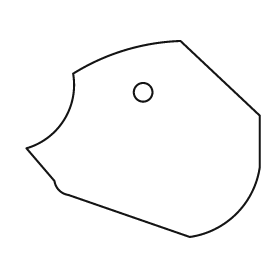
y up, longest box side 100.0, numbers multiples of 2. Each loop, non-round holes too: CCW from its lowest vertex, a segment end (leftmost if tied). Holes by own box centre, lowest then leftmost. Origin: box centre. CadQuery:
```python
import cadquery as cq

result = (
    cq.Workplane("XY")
    .moveTo(20.0, -42.0)
    .threePointArc((40.0, -32.0), (50.0, -12.0))
    .lineTo(50.0, 10.0)
    .lineTo(16.0, 42.0)
    .threePointArc((-8.0, 38.0), (-30.0, 28.0))
    .threePointArc((-34.0, 8.0), (-50.0, -4.0))
    .lineTo(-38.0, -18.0)
    .threePointArc((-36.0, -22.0), (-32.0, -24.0))
    .close()
    .moveTo(0.0, 20.0)
    .circle(4.0)
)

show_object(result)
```